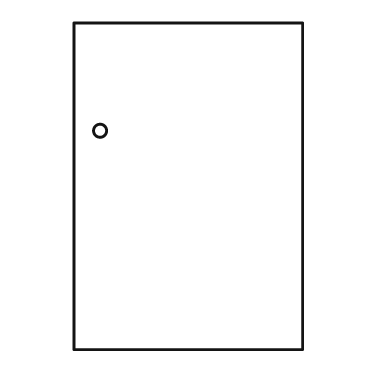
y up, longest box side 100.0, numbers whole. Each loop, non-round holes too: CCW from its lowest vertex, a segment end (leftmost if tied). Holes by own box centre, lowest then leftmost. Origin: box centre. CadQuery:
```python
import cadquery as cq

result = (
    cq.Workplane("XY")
    .moveTo(-35.0, -50.0)
    .lineTo(35.0, -50.0)
    .lineTo(35.0, 50.0)
    .lineTo(-35.0, 50.0)
    .close()
    .moveTo(-27.0, 17.0)
    .circle(2.0)
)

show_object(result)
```